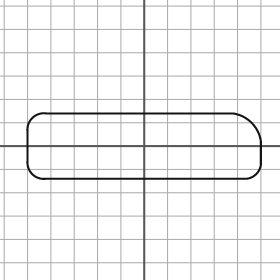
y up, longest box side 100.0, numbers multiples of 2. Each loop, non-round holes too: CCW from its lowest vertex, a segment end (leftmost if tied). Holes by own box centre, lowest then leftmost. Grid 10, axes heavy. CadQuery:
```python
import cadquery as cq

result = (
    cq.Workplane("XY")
    .moveTo(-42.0, -14.0)
    .lineTo(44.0, -14.0)
    .threePointArc((48.0, -12.0), (50.0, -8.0))
    .lineTo(50.0, 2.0)
    .threePointArc((46.0, 10.0), (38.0, 14.0))
    .lineTo(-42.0, 14.0)
    .threePointArc((-48.0, 12.0), (-50.0, 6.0))
    .lineTo(-50.0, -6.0)
    .threePointArc((-48.0, -12.0), (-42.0, -14.0))
    .close()
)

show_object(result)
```